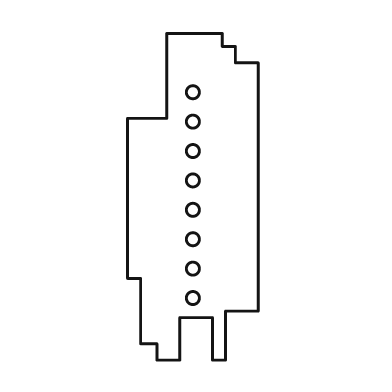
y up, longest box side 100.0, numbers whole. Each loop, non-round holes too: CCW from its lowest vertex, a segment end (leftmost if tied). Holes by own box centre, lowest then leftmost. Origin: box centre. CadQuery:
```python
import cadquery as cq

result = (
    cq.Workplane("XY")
    .moveTo(-11.0, -50.0)
    .lineTo(-4.0, -50.0)
    .lineTo(-4.0, -37.0)
    .lineTo(6.0, -37.0)
    .lineTo(6.0, -50.0)
    .lineTo(10.0, -50.0)
    .lineTo(10.0, -35.0)
    .lineTo(20.0, -35.0)
    .lineTo(20.0, 41.0)
    .lineTo(13.0, 41.0)
    .lineTo(13.0, 46.0)
    .lineTo(9.0, 46.0)
    .lineTo(9.0, 50.0)
    .lineTo(-8.0, 50.0)
    .lineTo(-8.0, 24.0)
    .lineTo(-20.0, 24.0)
    .lineTo(-20.0, -25.0)
    .lineTo(-16.0, -25.0)
    .lineTo(-16.0, -45.0)
    .lineTo(-11.0, -45.0)
    .close()
    .moveTo(0.0, -31.0)
    .circle(2.0)
    .moveTo(0.0, -22.0)
    .circle(2.0)
    .moveTo(0.0, -13.0)
    .circle(2.0)
    .moveTo(0.0, -4.0)
    .circle(2.0)
    .moveTo(0.0, 5.0)
    .circle(2.0)
    .moveTo(0.0, 14.0)
    .circle(2.0)
    .moveTo(0.0, 23.0)
    .circle(2.0)
    .moveTo(0.0, 32.0)
    .circle(2.0)
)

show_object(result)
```